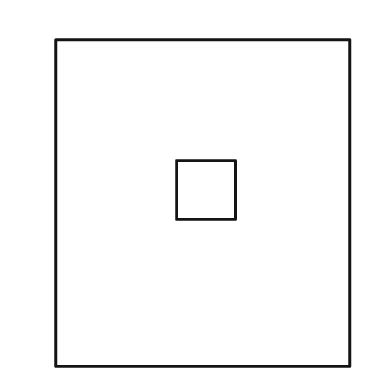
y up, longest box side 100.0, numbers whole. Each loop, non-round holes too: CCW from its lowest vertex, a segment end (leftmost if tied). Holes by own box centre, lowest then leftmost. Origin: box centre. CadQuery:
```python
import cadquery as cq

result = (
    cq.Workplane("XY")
    .moveTo(-45.0, -50.0)
    .lineTo(45.0, -50.0)
    .lineTo(45.0, 50.0)
    .lineTo(-45.0, 50.0)
    .close()
    .moveTo(-8.0, -5.0)
    .lineTo(10.0, -5.0)
    .lineTo(10.0, 13.0)
    .lineTo(-8.0, 13.0)
    .close()
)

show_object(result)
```